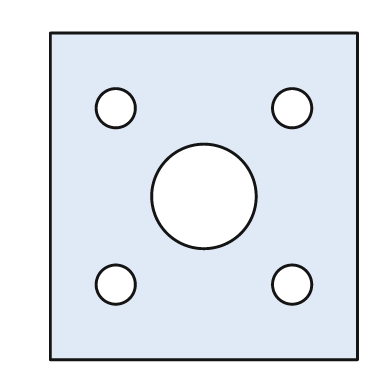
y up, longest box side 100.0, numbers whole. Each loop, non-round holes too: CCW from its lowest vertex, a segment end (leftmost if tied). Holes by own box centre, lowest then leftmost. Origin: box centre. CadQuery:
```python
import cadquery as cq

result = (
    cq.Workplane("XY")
    .moveTo(-47.0, -50.0)
    .lineTo(47.0, -50.0)
    .lineTo(47.0, 50.0)
    .lineTo(-47.0, 50.0)
    .close()
    .moveTo(-27.0, -27.0)
    .circle(6.0)
    .moveTo(27.0, -27.0)
    .circle(6.0)
    .moveTo(0.0, 0.0)
    .circle(16.0)
    .moveTo(-27.0, 27.0)
    .circle(6.0)
    .moveTo(27.0, 27.0)
    .circle(6.0)
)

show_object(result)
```